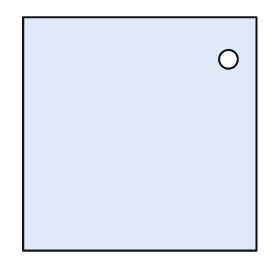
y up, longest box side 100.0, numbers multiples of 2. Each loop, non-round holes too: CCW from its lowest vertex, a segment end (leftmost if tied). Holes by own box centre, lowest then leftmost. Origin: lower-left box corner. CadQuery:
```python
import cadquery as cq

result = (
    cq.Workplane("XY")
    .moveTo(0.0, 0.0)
    .lineTo(100.0, 0.0)
    .lineTo(100.0, 100.0)
    .lineTo(0.0, 100.0)
    .close()
    .moveTo(88.0, 82.0)
    .circle(4.0)
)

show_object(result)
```